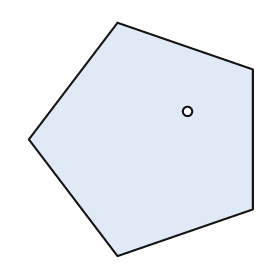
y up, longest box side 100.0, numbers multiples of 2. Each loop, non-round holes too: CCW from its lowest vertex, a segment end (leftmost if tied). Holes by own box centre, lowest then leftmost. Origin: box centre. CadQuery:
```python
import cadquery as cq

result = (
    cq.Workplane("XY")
    .moveTo(-10.0, -50.0)
    .lineTo(48.0, -30.0)
    .lineTo(48.0, 30.0)
    .lineTo(-10.0, 50.0)
    .lineTo(-48.0, 0.0)
    .close()
    .moveTo(20.0, 12.0)
    .circle(2.0)
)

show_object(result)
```